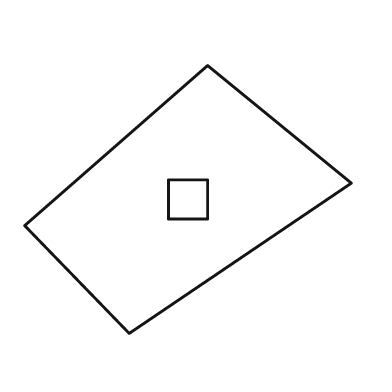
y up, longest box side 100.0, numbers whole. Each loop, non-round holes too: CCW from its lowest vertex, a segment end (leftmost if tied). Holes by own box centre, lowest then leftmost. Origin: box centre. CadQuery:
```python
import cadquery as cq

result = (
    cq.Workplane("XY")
    .moveTo(-18.0, -41.0)
    .lineTo(50.0, 5.0)
    .lineTo(6.0, 41.0)
    .lineTo(-50.0, -8.0)
    .close()
    .moveTo(-6.0, -6.0)
    .lineTo(6.0, -6.0)
    .lineTo(6.0, 6.0)
    .lineTo(-6.0, 6.0)
    .close()
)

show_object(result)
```